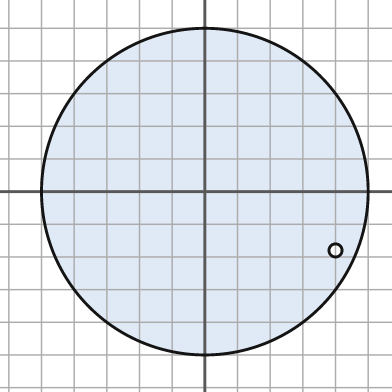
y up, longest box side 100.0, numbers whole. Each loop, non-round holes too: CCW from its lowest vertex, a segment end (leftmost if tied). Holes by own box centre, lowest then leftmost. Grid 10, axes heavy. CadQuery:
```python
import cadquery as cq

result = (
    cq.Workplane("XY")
    .moveTo(0.0, 0.0)
    .circle(50.0)
    .moveTo(40.0, -18.0)
    .circle(2.0)
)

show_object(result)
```